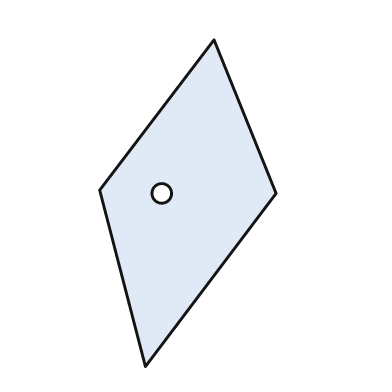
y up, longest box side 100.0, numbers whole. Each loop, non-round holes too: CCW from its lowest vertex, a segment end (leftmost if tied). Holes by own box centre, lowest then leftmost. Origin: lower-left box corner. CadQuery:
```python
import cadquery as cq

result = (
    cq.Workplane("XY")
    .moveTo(14.0, 0.0)
    .lineTo(54.0, 53.0)
    .lineTo(35.0, 100.0)
    .lineTo(0.0, 54.0)
    .close()
    .moveTo(19.0, 53.0)
    .circle(3.0)
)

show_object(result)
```